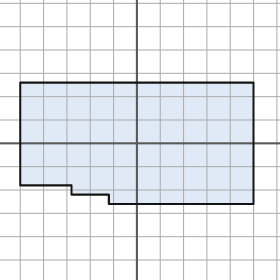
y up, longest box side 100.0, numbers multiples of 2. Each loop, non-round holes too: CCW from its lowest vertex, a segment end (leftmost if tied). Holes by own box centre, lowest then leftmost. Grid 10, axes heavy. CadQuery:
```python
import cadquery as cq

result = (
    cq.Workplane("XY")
    .moveTo(-12.0, -26.0)
    .lineTo(50.0, -26.0)
    .lineTo(50.0, 26.0)
    .lineTo(-50.0, 26.0)
    .lineTo(-50.0, -18.0)
    .lineTo(-28.0, -18.0)
    .lineTo(-28.0, -22.0)
    .lineTo(-12.0, -22.0)
    .close()
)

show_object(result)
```